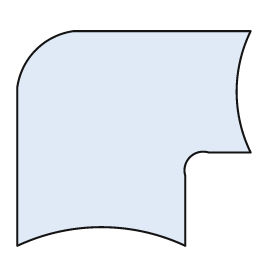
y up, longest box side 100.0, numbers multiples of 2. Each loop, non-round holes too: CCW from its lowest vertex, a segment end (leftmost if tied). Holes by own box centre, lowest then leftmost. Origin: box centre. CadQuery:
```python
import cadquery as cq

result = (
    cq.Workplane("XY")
    .moveTo(-50.0, -46.0)
    .threePointArc((-14.0, -38.0), (22.0, -46.0))
    .lineTo(22.0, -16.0)
    .threePointArc((24.0, -8.0), (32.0, -6.0))
    .lineTo(50.0, -6.0)
    .threePointArc((44.0, 20.0), (50.0, 46.0))
    .lineTo(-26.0, 46.0)
    .threePointArc((-42.0, 38.0), (-50.0, 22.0))
    .close()
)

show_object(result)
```